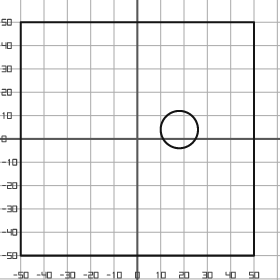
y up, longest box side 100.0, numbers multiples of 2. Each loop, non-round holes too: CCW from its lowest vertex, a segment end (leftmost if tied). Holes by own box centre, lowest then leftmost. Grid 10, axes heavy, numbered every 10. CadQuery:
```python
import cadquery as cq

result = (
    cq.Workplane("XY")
    .moveTo(-50.0, -50.0)
    .lineTo(50.0, -50.0)
    .lineTo(50.0, 50.0)
    .lineTo(-50.0, 50.0)
    .close()
    .moveTo(18.0, 4.0)
    .circle(8.0)
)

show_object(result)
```